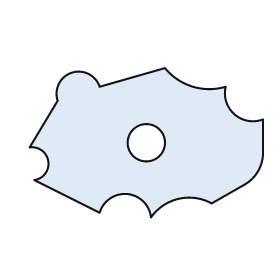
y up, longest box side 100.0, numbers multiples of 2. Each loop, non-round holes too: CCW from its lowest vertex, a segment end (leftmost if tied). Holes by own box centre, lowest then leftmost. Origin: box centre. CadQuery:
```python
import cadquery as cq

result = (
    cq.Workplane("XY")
    .moveTo(2.0, -32.0)
    .threePointArc((14.0, -24.0), (28.0, -26.0))
    .lineTo(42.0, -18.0)
    .threePointArc((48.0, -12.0), (50.0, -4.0))
    .lineTo(50.0, 10.0)
    .threePointArc((38.0, 12.0), (34.0, 24.0))
    .threePointArc((20.0, 24.0), (8.0, 32.0))
    .lineTo(-20.0, 24.0)
    .threePointArc((-32.0, 30.0), (-38.0, 18.0))
    .lineTo(-50.0, -2.0)
    .threePointArc((-42.0, -8.0), (-48.0, -16.0))
    .lineTo(-20.0, -30.0)
    .threePointArc((-8.0, -22.0), (2.0, -32.0))
    .close()
    .moveTo(0.0, 0.0)
    .circle(8.0)
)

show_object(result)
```